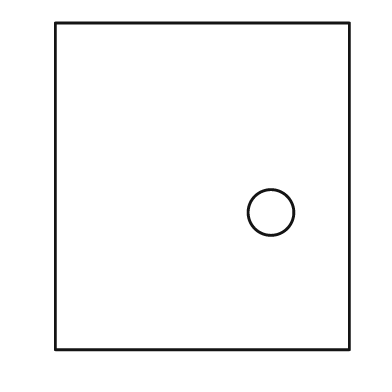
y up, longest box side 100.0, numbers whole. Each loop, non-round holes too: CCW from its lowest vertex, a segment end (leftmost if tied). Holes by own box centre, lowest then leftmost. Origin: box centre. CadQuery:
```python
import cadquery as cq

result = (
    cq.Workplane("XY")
    .moveTo(-45.0, -50.0)
    .lineTo(45.0, -50.0)
    .lineTo(45.0, 50.0)
    .lineTo(-45.0, 50.0)
    .close()
    .moveTo(21.0, -8.0)
    .circle(7.0)
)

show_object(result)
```